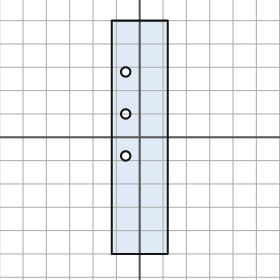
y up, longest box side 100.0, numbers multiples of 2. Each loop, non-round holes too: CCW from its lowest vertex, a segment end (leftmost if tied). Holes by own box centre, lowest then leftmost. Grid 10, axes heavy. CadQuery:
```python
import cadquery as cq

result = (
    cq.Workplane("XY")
    .moveTo(-12.0, -50.0)
    .lineTo(12.0, -50.0)
    .lineTo(12.0, 50.0)
    .lineTo(-12.0, 50.0)
    .close()
    .moveTo(-6.0, -8.0)
    .circle(2.0)
    .moveTo(-6.0, 10.0)
    .circle(2.0)
    .moveTo(-6.0, 28.0)
    .circle(2.0)
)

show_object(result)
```